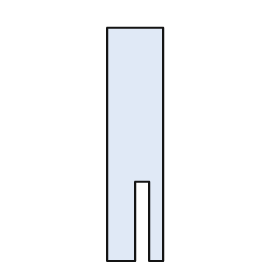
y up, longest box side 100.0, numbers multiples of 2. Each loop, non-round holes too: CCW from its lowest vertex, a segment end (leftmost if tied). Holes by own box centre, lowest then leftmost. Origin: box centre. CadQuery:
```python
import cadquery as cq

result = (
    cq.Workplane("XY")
    .moveTo(-12.0, -50.0)
    .lineTo(0.0, -50.0)
    .lineTo(0.0, -16.0)
    .lineTo(6.0, -16.0)
    .lineTo(6.0, -50.0)
    .lineTo(12.0, -50.0)
    .lineTo(12.0, 50.0)
    .lineTo(-12.0, 50.0)
    .close()
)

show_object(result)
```